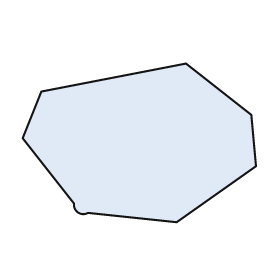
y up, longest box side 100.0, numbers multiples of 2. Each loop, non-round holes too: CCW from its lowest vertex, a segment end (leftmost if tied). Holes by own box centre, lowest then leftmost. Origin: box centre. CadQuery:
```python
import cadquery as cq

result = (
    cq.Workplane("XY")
    .moveTo(16.0, -34.0)
    .lineTo(50.0, -10.0)
    .lineTo(48.0, 12.0)
    .lineTo(20.0, 34.0)
    .lineTo(-42.0, 22.0)
    .lineTo(-50.0, 2.0)
    .lineTo(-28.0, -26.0)
    .threePointArc((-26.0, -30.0), (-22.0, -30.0))
    .close()
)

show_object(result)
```